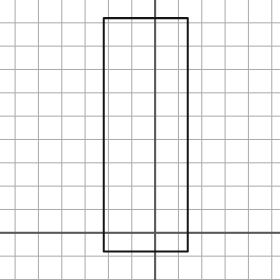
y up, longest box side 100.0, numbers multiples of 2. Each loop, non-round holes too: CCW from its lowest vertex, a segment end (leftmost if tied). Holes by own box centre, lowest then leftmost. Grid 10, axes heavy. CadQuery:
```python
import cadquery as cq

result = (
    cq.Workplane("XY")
    .moveTo(-22.0, -8.0)
    .lineTo(14.0, -8.0)
    .lineTo(14.0, 92.0)
    .lineTo(-22.0, 92.0)
    .close()
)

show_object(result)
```